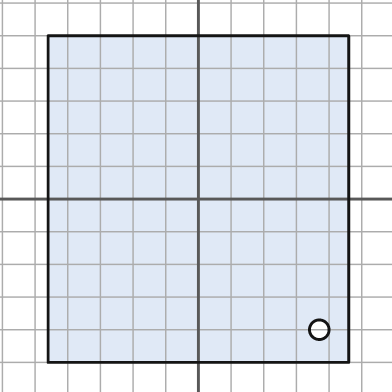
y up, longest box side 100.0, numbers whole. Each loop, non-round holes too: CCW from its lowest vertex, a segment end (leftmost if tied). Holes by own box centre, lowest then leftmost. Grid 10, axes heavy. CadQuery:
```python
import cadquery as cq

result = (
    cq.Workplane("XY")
    .moveTo(-46.0, -50.0)
    .lineTo(46.0, -50.0)
    .lineTo(46.0, 50.0)
    .lineTo(-46.0, 50.0)
    .close()
    .moveTo(37.0, -40.0)
    .circle(3.0)
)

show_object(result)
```